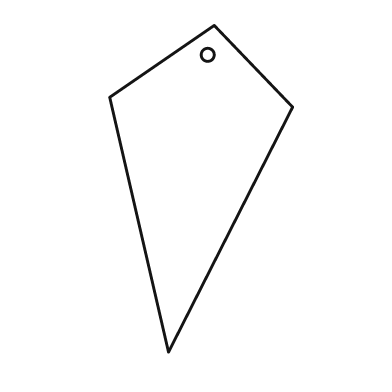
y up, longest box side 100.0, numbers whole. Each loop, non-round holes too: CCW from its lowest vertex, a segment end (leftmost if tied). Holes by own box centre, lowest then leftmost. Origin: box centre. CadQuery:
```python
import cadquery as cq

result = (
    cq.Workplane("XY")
    .moveTo(-10.0, -50.0)
    .lineTo(28.0, 25.0)
    .lineTo(4.0, 50.0)
    .lineTo(-28.0, 28.0)
    .close()
    .moveTo(2.0, 41.0)
    .circle(2.0)
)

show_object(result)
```